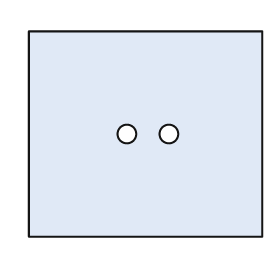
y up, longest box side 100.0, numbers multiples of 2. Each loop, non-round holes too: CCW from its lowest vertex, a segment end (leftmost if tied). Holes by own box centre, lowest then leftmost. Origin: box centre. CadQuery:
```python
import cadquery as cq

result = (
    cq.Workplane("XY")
    .moveTo(-50.0, -44.0)
    .lineTo(50.0, -44.0)
    .lineTo(50.0, 44.0)
    .lineTo(-50.0, 44.0)
    .close()
    .moveTo(-8.0, 0.0)
    .circle(4.0)
    .moveTo(10.0, 0.0)
    .circle(4.0)
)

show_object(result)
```